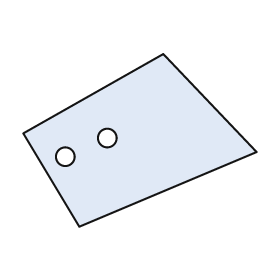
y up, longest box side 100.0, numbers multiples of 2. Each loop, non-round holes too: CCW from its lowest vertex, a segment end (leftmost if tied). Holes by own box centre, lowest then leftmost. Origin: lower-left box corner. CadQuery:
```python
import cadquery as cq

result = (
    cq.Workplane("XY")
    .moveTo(24.0, 0.0)
    .lineTo(100.0, 32.0)
    .lineTo(60.0, 74.0)
    .lineTo(0.0, 40.0)
    .close()
    .moveTo(18.0, 30.0)
    .circle(4.0)
    .moveTo(36.0, 38.0)
    .circle(4.0)
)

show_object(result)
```